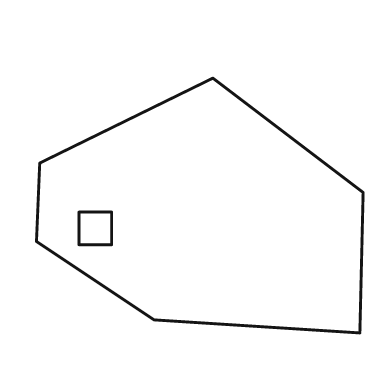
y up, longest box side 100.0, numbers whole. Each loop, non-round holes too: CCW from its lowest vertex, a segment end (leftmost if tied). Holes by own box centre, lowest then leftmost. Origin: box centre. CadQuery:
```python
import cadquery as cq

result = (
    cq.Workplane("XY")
    .moveTo(49.0, -39.0)
    .lineTo(50.0, 4.0)
    .lineTo(4.0, 39.0)
    .lineTo(-49.0, 13.0)
    .lineTo(-50.0, -11.0)
    .lineTo(-14.0, -35.0)
    .close()
    .moveTo(-37.0, -12.0)
    .lineTo(-27.0, -12.0)
    .lineTo(-27.0, -2.0)
    .lineTo(-37.0, -2.0)
    .close()
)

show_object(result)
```